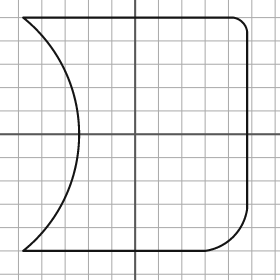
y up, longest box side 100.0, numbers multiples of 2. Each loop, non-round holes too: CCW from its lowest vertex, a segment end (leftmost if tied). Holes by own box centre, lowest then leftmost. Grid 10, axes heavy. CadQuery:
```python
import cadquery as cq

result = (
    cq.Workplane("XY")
    .moveTo(-48.0, -50.0)
    .lineTo(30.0, -50.0)
    .threePointArc((42.0, -44.0), (48.0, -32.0))
    .lineTo(48.0, 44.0)
    .threePointArc((46.0, 48.0), (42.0, 50.0))
    .lineTo(-48.0, 50.0)
    .threePointArc((-24.0, 0.0), (-48.0, -50.0))
    .close()
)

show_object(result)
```